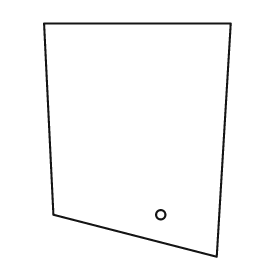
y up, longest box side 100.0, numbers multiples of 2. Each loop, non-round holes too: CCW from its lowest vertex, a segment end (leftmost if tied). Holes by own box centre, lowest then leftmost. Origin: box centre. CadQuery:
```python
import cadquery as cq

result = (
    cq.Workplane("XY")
    .moveTo(34.0, -50.0)
    .lineTo(40.0, 50.0)
    .lineTo(-40.0, 50.0)
    .lineTo(-36.0, -32.0)
    .close()
    .moveTo(10.0, -32.0)
    .circle(2.0)
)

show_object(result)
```